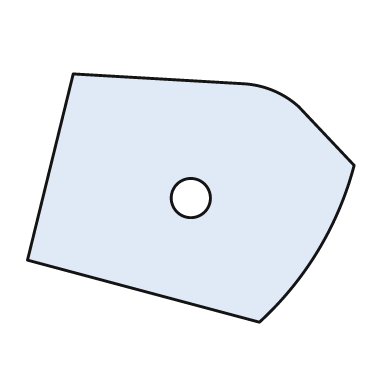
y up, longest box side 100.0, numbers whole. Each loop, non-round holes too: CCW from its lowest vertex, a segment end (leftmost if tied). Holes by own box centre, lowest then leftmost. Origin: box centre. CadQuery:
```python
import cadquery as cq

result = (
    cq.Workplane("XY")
    .moveTo(21.0, -38.0)
    .threePointArc((39.0, -16.0), (50.0, 10.0))
    .lineTo(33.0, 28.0)
    .threePointArc((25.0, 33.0), (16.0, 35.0))
    .lineTo(-36.0, 38.0)
    .lineTo(-50.0, -19.0)
    .close()
    .moveTo(0.0, 0.0)
    .circle(6.0)
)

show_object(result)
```